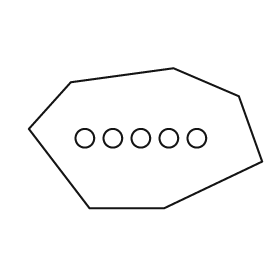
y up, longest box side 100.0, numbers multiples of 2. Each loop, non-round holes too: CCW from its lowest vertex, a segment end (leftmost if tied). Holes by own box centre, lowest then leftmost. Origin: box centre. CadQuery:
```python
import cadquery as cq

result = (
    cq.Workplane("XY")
    .moveTo(-24.0, -30.0)
    .lineTo(8.0, -30.0)
    .lineTo(50.0, -10.0)
    .lineTo(40.0, 18.0)
    .lineTo(12.0, 30.0)
    .lineTo(-32.0, 24.0)
    .lineTo(-50.0, 4.0)
    .close()
    .moveTo(-26.0, 0.0)
    .circle(4.0)
    .moveTo(-14.0, 0.0)
    .circle(4.0)
    .moveTo(-2.0, 0.0)
    .circle(4.0)
    .moveTo(10.0, 0.0)
    .circle(4.0)
    .moveTo(22.0, 0.0)
    .circle(4.0)
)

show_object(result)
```